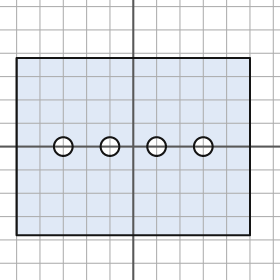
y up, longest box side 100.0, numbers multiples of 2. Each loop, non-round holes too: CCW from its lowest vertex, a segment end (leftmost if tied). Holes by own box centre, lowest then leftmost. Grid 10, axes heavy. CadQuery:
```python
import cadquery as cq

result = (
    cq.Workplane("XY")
    .moveTo(-50.0, -38.0)
    .lineTo(50.0, -38.0)
    .lineTo(50.0, 38.0)
    .lineTo(-50.0, 38.0)
    .close()
    .moveTo(-30.0, 0.0)
    .circle(4.0)
    .moveTo(-10.0, 0.0)
    .circle(4.0)
    .moveTo(10.0, 0.0)
    .circle(4.0)
    .moveTo(30.0, 0.0)
    .circle(4.0)
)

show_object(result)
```